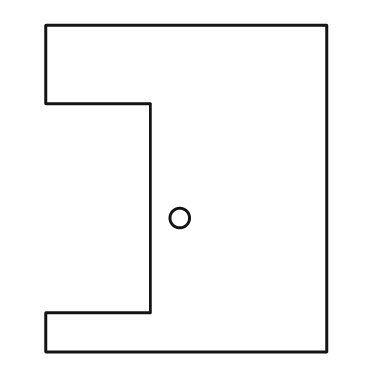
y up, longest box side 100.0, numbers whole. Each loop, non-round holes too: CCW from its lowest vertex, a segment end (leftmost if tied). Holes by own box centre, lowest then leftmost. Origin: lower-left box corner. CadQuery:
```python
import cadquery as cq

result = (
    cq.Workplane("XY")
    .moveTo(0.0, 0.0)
    .lineTo(86.0, 0.0)
    .lineTo(86.0, 100.0)
    .lineTo(0.0, 100.0)
    .lineTo(0.0, 76.0)
    .lineTo(32.0, 76.0)
    .lineTo(32.0, 12.0)
    .lineTo(0.0, 12.0)
    .close()
    .moveTo(41.0, 41.0)
    .circle(3.0)
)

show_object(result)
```